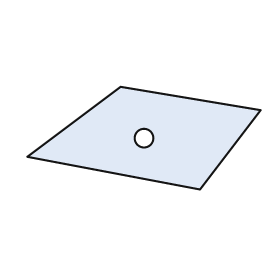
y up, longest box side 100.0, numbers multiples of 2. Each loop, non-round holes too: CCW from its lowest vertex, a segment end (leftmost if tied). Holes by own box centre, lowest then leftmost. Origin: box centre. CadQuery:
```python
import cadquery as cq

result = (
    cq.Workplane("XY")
    .moveTo(24.0, -22.0)
    .lineTo(50.0, 12.0)
    .lineTo(-10.0, 22.0)
    .lineTo(-50.0, -8.0)
    .close()
    .moveTo(0.0, 0.0)
    .circle(4.0)
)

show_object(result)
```